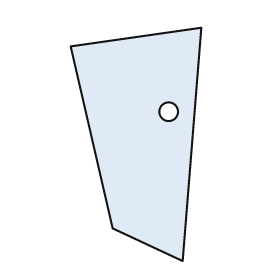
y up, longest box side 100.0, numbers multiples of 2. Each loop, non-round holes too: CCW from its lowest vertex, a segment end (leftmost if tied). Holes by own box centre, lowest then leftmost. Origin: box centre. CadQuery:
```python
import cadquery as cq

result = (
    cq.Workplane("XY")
    .moveTo(20.0, -50.0)
    .lineTo(28.0, 50.0)
    .lineTo(-28.0, 42.0)
    .lineTo(-10.0, -36.0)
    .close()
    .moveTo(14.0, 14.0)
    .circle(4.0)
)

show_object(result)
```